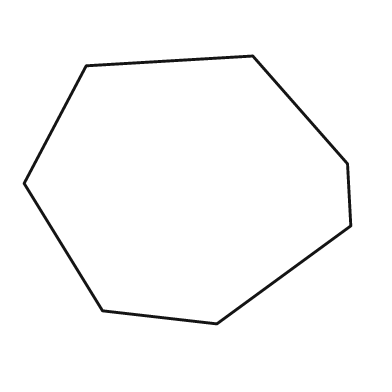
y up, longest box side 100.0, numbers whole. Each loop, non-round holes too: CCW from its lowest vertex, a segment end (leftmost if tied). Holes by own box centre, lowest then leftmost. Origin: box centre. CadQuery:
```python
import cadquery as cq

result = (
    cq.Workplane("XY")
    .moveTo(9.0, -41.0)
    .lineTo(50.0, -11.0)
    .lineTo(49.0, 8.0)
    .lineTo(20.0, 41.0)
    .lineTo(-31.0, 38.0)
    .lineTo(-50.0, 2.0)
    .lineTo(-26.0, -37.0)
    .close()
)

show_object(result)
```